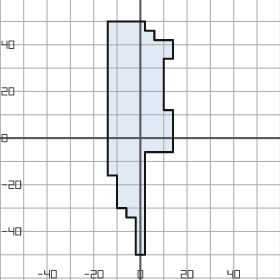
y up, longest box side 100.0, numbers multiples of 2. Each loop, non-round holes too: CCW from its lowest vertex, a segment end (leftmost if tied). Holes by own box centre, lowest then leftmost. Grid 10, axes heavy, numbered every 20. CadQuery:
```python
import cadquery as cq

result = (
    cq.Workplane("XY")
    .moveTo(-2.0, -50.0)
    .lineTo(2.0, -50.0)
    .lineTo(2.0, -6.0)
    .lineTo(14.0, -6.0)
    .lineTo(14.0, 12.0)
    .lineTo(10.0, 12.0)
    .lineTo(10.0, 34.0)
    .lineTo(14.0, 34.0)
    .lineTo(14.0, 42.0)
    .lineTo(6.0, 42.0)
    .lineTo(6.0, 46.0)
    .lineTo(2.0, 46.0)
    .lineTo(2.0, 50.0)
    .lineTo(-14.0, 50.0)
    .lineTo(-14.0, -16.0)
    .lineTo(-10.0, -16.0)
    .lineTo(-10.0, -30.0)
    .lineTo(-6.0, -30.0)
    .lineTo(-6.0, -34.0)
    .lineTo(-2.0, -34.0)
    .close()
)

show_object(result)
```